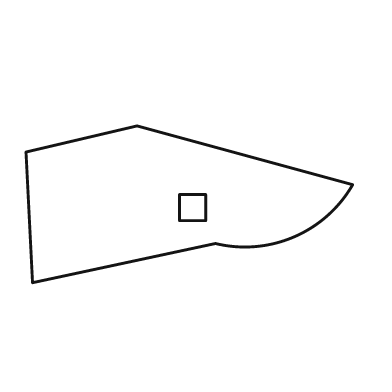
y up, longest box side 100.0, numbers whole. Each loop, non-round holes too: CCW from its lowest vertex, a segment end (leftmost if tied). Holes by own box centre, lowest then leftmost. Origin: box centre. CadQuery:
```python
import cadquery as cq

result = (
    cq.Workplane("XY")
    .moveTo(-48.0, -24.0)
    .lineTo(8.0, -12.0)
    .threePointArc((32.0, -10.0), (50.0, 6.0))
    .lineTo(-16.0, 24.0)
    .lineTo(-50.0, 16.0)
    .close()
    .moveTo(-3.0, -5.0)
    .lineTo(5.0, -5.0)
    .lineTo(5.0, 3.0)
    .lineTo(-3.0, 3.0)
    .close()
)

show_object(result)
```